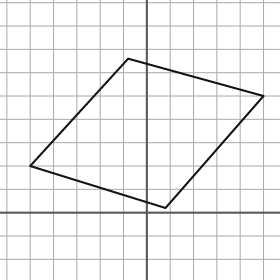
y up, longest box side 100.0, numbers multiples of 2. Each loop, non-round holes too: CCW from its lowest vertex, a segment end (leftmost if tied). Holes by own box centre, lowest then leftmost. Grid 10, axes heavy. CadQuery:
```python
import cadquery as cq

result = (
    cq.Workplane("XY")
    .moveTo(8.0, 2.0)
    .lineTo(50.0, 50.0)
    .lineTo(-8.0, 66.0)
    .lineTo(-50.0, 20.0)
    .close()
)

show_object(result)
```